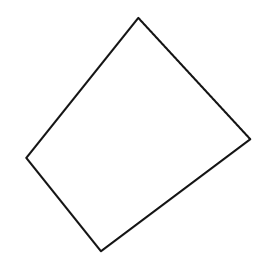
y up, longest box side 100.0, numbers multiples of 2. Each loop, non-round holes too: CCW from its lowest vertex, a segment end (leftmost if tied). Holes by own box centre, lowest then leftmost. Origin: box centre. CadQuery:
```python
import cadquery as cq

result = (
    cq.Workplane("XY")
    .moveTo(-16.0, -50.0)
    .lineTo(48.0, -2.0)
    .lineTo(0.0, 50.0)
    .lineTo(-48.0, -10.0)
    .close()
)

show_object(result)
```